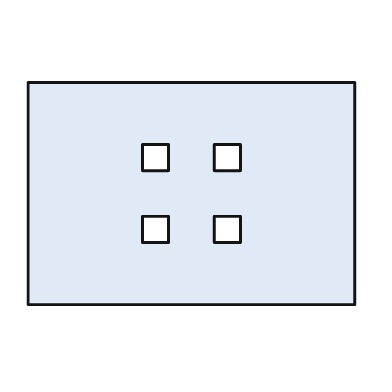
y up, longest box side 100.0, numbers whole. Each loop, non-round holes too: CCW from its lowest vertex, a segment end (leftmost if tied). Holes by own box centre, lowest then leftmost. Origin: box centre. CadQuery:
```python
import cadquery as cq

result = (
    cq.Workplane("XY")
    .moveTo(-50.0, -34.0)
    .lineTo(50.0, -34.0)
    .lineTo(50.0, 34.0)
    .lineTo(-50.0, 34.0)
    .close()
    .moveTo(-15.0, -15.0)
    .lineTo(-7.0, -15.0)
    .lineTo(-7.0, -7.0)
    .lineTo(-15.0, -7.0)
    .close()
    .moveTo(7.0, -15.0)
    .lineTo(15.0, -15.0)
    .lineTo(15.0, -7.0)
    .lineTo(7.0, -7.0)
    .close()
    .moveTo(-15.0, 7.0)
    .lineTo(-7.0, 7.0)
    .lineTo(-7.0, 15.0)
    .lineTo(-15.0, 15.0)
    .close()
    .moveTo(7.0, 7.0)
    .lineTo(15.0, 7.0)
    .lineTo(15.0, 15.0)
    .lineTo(7.0, 15.0)
    .close()
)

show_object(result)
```